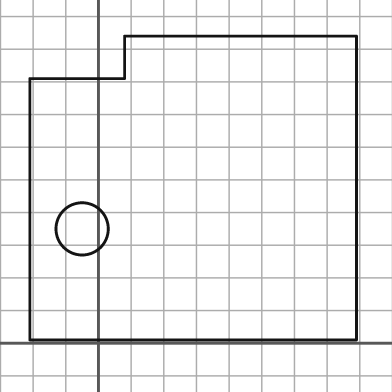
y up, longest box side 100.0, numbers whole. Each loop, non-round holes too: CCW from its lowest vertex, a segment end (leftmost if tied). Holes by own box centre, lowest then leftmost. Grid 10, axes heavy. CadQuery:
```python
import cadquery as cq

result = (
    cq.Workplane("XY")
    .moveTo(-21.0, 1.0)
    .lineTo(79.0, 1.0)
    .lineTo(79.0, 94.0)
    .lineTo(8.0, 94.0)
    .lineTo(8.0, 81.0)
    .lineTo(-21.0, 81.0)
    .close()
    .moveTo(-5.0, 35.0)
    .circle(8.0)
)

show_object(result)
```